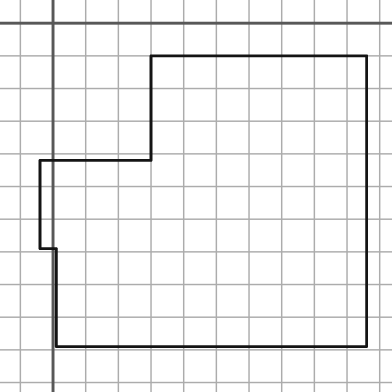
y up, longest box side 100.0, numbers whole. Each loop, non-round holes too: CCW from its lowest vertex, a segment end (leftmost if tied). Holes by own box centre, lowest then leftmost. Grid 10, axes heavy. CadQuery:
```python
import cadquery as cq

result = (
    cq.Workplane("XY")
    .moveTo(1.0, -99.0)
    .lineTo(96.0, -99.0)
    .lineTo(96.0, -10.0)
    .lineTo(30.0, -10.0)
    .lineTo(30.0, -42.0)
    .lineTo(-4.0, -42.0)
    .lineTo(-4.0, -69.0)
    .lineTo(1.0, -69.0)
    .close()
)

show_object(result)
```